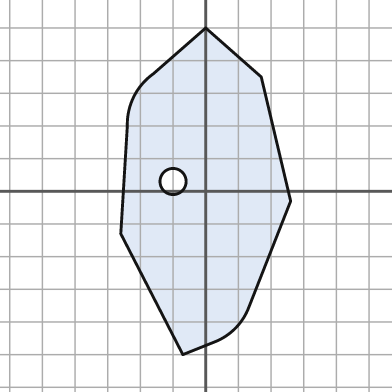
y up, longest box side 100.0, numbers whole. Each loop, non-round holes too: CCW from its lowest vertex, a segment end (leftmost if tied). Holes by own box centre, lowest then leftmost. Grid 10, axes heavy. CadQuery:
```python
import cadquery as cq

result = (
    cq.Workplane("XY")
    .moveTo(-7.0, -50.0)
    .lineTo(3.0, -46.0)
    .threePointArc((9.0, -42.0), (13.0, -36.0))
    .lineTo(26.0, -3.0)
    .lineTo(17.0, 35.0)
    .lineTo(0.0, 50.0)
    .lineTo(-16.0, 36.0)
    .threePointArc((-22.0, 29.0), (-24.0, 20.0))
    .lineTo(-26.0, -13.0)
    .close()
    .moveTo(-10.0, 3.0)
    .circle(4.0)
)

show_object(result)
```